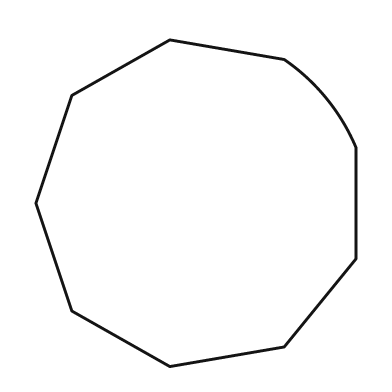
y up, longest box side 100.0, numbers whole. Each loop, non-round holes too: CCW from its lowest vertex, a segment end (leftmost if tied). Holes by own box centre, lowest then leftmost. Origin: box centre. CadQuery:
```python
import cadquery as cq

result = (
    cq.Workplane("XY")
    .moveTo(-8.0, -50.0)
    .lineTo(27.0, -44.0)
    .lineTo(49.0, -17.0)
    .lineTo(49.0, 17.0)
    .threePointArc((40.0, 32.0), (27.0, 44.0))
    .lineTo(-8.0, 50.0)
    .lineTo(-38.0, 33.0)
    .lineTo(-49.0, 0.0)
    .lineTo(-38.0, -33.0)
    .close()
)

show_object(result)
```